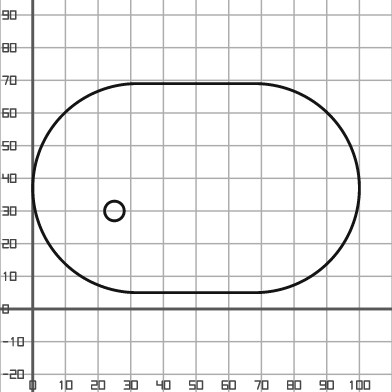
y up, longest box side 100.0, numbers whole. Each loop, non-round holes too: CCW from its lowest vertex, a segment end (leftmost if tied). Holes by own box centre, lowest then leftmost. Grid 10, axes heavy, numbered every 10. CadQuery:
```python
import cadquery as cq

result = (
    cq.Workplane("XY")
    .moveTo(32.0, 5.0)
    .lineTo(68.0, 5.0)
    .threePointArc((100.0, 37.0), (68.0, 69.0))
    .lineTo(32.0, 69.0)
    .threePointArc((0.0, 37.0), (32.0, 5.0))
    .close()
    .moveTo(25.0, 30.0)
    .circle(3.0)
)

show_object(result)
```